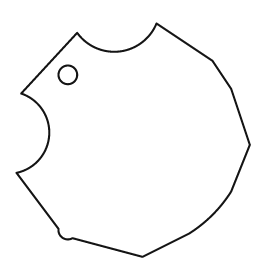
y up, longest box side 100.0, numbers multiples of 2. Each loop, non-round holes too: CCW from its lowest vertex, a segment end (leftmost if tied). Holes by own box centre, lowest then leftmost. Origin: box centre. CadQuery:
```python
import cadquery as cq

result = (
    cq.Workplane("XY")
    .moveTo(4.0, -50.0)
    .lineTo(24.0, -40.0)
    .threePointArc((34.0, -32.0), (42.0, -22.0))
    .lineTo(50.0, -2.0)
    .lineTo(42.0, 22.0)
    .lineTo(34.0, 34.0)
    .lineTo(10.0, 50.0)
    .threePointArc((-6.0, 38.0), (-24.0, 46.0))
    .lineTo(-48.0, 20.0)
    .threePointArc((-36.0, 2.0), (-50.0, -14.0))
    .lineTo(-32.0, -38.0)
    .threePointArc((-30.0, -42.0), (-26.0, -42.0))
    .close()
    .moveTo(-28.0, 28.0)
    .circle(4.0)
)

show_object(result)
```